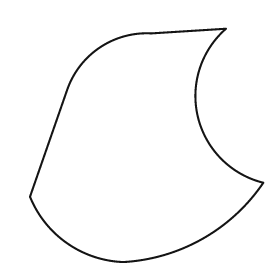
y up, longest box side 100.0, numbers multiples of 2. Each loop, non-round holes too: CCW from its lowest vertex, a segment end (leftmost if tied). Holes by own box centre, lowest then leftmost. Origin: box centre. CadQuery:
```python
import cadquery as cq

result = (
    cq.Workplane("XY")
    .moveTo(-10.0, -50.0)
    .threePointArc((24.0, -40.0), (50.0, -16.0))
    .threePointArc((22.0, 12.0), (34.0, 50.0))
    .lineTo(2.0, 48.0)
    .threePointArc((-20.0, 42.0), (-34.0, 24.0))
    .lineTo(-50.0, -22.0)
    .threePointArc((-34.0, -42.0), (-10.0, -50.0))
    .close()
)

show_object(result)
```